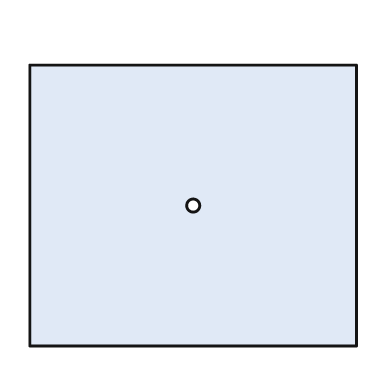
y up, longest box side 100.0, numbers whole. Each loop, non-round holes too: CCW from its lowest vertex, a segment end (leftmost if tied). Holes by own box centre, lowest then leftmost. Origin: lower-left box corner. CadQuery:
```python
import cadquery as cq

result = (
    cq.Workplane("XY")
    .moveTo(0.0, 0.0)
    .lineTo(100.0, 0.0)
    .lineTo(100.0, 86.0)
    .lineTo(0.0, 86.0)
    .close()
    .moveTo(50.0, 43.0)
    .circle(2.0)
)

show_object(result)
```